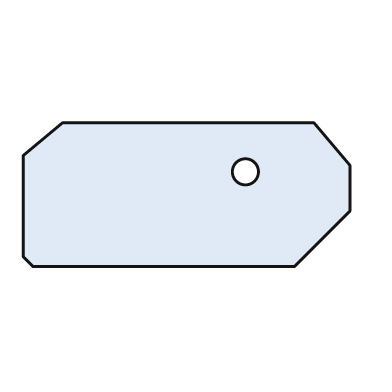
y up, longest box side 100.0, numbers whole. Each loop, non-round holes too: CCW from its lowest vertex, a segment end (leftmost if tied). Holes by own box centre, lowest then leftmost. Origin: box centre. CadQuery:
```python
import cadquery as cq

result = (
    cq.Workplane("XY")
    .moveTo(-47.0, -22.0)
    .lineTo(33.0, -22.0)
    .lineTo(50.0, -5.0)
    .lineTo(50.0, 9.0)
    .lineTo(39.0, 22.0)
    .lineTo(-38.0, 22.0)
    .lineTo(-50.0, 12.0)
    .lineTo(-50.0, -19.0)
    .close()
    .moveTo(18.0, 7.0)
    .circle(4.0)
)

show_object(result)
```